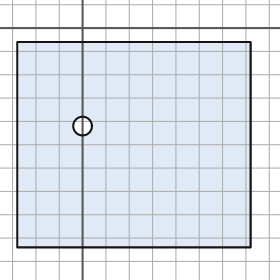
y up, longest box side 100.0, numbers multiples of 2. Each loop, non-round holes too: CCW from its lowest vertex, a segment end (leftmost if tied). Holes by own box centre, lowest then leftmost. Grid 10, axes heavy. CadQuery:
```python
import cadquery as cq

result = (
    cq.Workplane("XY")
    .moveTo(-28.0, -94.0)
    .lineTo(72.0, -94.0)
    .lineTo(72.0, -6.0)
    .lineTo(-28.0, -6.0)
    .close()
    .moveTo(0.0, -42.0)
    .circle(4.0)
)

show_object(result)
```